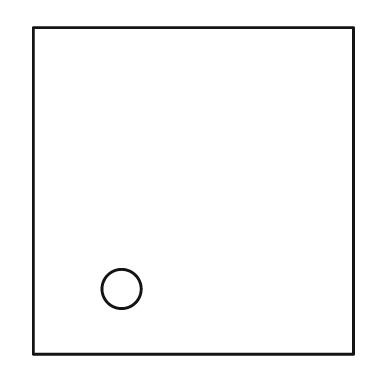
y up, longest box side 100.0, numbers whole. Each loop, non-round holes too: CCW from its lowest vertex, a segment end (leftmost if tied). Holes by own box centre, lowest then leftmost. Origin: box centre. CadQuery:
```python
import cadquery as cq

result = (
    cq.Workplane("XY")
    .moveTo(-49.0, -50.0)
    .lineTo(49.0, -50.0)
    .lineTo(49.0, 50.0)
    .lineTo(-49.0, 50.0)
    .close()
    .moveTo(-22.0, -30.0)
    .circle(6.0)
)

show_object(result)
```